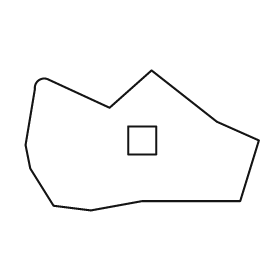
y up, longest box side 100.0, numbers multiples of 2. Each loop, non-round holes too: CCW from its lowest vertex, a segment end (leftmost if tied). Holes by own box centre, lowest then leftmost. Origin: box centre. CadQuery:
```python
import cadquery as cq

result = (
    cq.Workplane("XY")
    .moveTo(-22.0, -30.0)
    .lineTo(0.0, -26.0)
    .lineTo(42.0, -26.0)
    .lineTo(50.0, 0.0)
    .lineTo(32.0, 8.0)
    .lineTo(4.0, 30.0)
    .lineTo(-14.0, 14.0)
    .lineTo(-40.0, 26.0)
    .threePointArc((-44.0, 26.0), (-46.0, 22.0))
    .lineTo(-50.0, -2.0)
    .lineTo(-48.0, -12.0)
    .lineTo(-38.0, -28.0)
    .close()
    .moveTo(-6.0, -6.0)
    .lineTo(6.0, -6.0)
    .lineTo(6.0, 6.0)
    .lineTo(-6.0, 6.0)
    .close()
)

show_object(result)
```